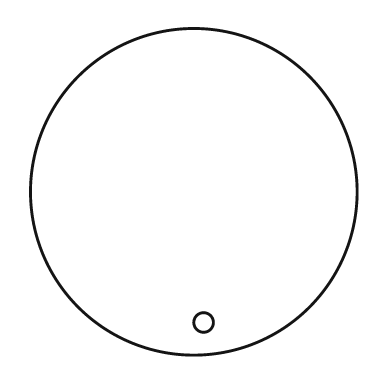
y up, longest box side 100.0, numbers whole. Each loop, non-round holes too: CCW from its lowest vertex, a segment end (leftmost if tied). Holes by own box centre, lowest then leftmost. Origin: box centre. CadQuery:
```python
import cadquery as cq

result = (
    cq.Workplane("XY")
    .moveTo(0.0, 0.0)
    .circle(50.0)
    .moveTo(3.0, -40.0)
    .circle(3.0)
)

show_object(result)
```